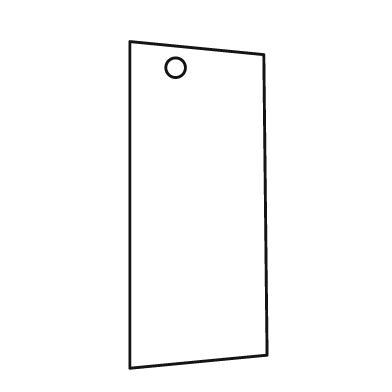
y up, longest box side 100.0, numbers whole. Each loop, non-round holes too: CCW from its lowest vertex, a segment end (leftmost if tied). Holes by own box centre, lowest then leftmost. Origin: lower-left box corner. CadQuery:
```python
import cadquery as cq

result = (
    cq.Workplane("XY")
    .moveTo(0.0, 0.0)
    .lineTo(42.0, 4.0)
    .lineTo(41.0, 96.0)
    .lineTo(0.0, 100.0)
    .close()
    .moveTo(14.0, 92.0)
    .circle(3.0)
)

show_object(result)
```